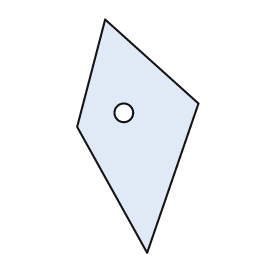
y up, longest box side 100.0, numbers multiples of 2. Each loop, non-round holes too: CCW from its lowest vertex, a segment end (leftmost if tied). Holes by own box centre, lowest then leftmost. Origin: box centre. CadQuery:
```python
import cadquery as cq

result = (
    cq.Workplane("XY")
    .moveTo(4.0, -50.0)
    .lineTo(26.0, 14.0)
    .lineTo(-14.0, 50.0)
    .lineTo(-26.0, 4.0)
    .close()
    .moveTo(-6.0, 10.0)
    .circle(4.0)
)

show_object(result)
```